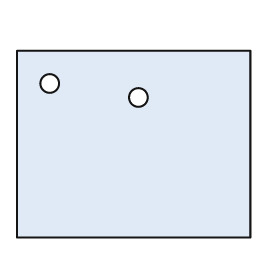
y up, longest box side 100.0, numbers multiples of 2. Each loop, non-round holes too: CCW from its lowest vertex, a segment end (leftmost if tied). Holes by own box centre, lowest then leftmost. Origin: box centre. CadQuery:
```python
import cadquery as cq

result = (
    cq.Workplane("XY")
    .moveTo(-50.0, -40.0)
    .lineTo(50.0, -40.0)
    .lineTo(50.0, 40.0)
    .lineTo(-50.0, 40.0)
    .close()
    .moveTo(2.0, 20.0)
    .circle(4.0)
    .moveTo(-36.0, 26.0)
    .circle(4.0)
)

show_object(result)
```